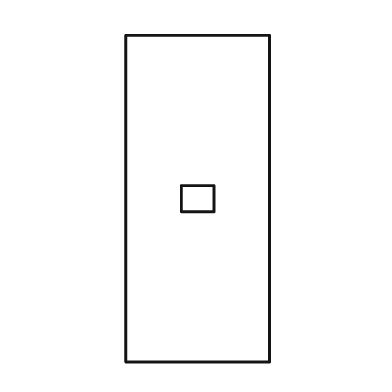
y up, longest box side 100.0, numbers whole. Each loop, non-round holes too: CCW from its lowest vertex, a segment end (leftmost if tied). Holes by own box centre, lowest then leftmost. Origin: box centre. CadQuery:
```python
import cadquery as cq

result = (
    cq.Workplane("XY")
    .moveTo(-22.0, -50.0)
    .lineTo(22.0, -50.0)
    .lineTo(22.0, 50.0)
    .lineTo(-22.0, 50.0)
    .close()
    .moveTo(-5.0, -4.0)
    .lineTo(5.0, -4.0)
    .lineTo(5.0, 4.0)
    .lineTo(-5.0, 4.0)
    .close()
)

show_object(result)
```